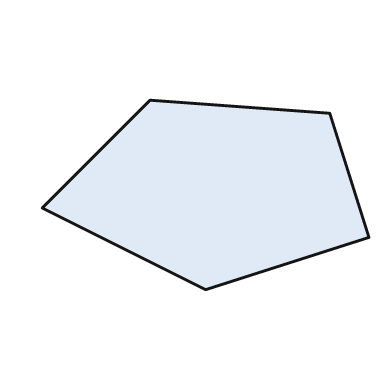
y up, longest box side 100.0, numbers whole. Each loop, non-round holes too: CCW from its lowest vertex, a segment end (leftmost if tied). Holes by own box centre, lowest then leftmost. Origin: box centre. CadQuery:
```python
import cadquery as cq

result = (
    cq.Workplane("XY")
    .moveTo(0.0, -29.0)
    .lineTo(50.0, -13.0)
    .lineTo(38.0, 25.0)
    .lineTo(-17.0, 29.0)
    .lineTo(-50.0, -4.0)
    .close()
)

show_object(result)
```